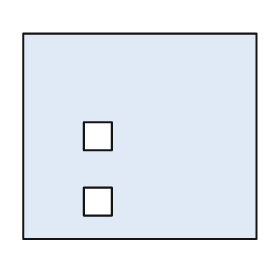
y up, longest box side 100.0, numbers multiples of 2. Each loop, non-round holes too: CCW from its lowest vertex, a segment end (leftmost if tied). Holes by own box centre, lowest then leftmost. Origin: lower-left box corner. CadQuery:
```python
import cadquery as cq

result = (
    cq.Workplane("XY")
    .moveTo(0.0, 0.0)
    .lineTo(100.0, 0.0)
    .lineTo(100.0, 88.0)
    .lineTo(0.0, 88.0)
    .close()
    .moveTo(26.0, 10.0)
    .lineTo(38.0, 10.0)
    .lineTo(38.0, 22.0)
    .lineTo(26.0, 22.0)
    .close()
    .moveTo(26.0, 38.0)
    .lineTo(38.0, 38.0)
    .lineTo(38.0, 50.0)
    .lineTo(26.0, 50.0)
    .close()
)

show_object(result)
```